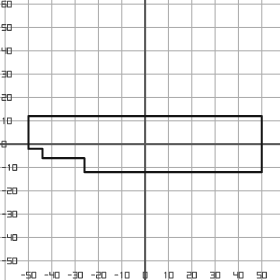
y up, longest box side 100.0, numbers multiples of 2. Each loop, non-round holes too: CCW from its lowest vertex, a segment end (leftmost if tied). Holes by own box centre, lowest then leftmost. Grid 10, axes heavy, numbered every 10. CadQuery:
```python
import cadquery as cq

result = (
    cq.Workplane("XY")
    .moveTo(-26.0, -12.0)
    .lineTo(50.0, -12.0)
    .lineTo(50.0, 12.0)
    .lineTo(-50.0, 12.0)
    .lineTo(-50.0, -2.0)
    .lineTo(-44.0, -2.0)
    .lineTo(-44.0, -6.0)
    .lineTo(-26.0, -6.0)
    .close()
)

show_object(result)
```